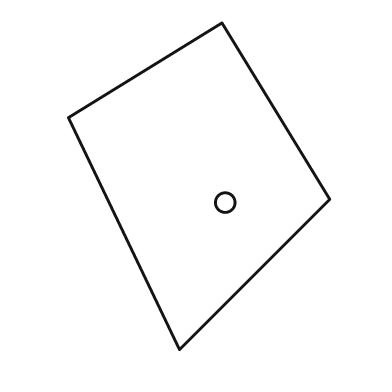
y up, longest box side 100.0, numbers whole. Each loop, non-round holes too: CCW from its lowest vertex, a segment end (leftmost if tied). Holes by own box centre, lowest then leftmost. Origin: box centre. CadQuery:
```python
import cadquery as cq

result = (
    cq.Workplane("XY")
    .moveTo(-6.0, -50.0)
    .lineTo(40.0, -4.0)
    .lineTo(7.0, 50.0)
    .lineTo(-40.0, 21.0)
    .close()
    .moveTo(8.0, -5.0)
    .circle(3.0)
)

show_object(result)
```